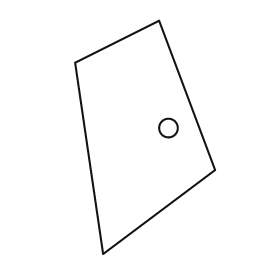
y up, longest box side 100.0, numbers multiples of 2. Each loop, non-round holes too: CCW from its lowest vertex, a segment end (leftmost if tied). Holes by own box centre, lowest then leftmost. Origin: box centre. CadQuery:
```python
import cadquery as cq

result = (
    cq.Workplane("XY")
    .moveTo(-18.0, -50.0)
    .lineTo(30.0, -14.0)
    .lineTo(6.0, 50.0)
    .lineTo(-30.0, 32.0)
    .close()
    .moveTo(10.0, 4.0)
    .circle(4.0)
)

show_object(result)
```